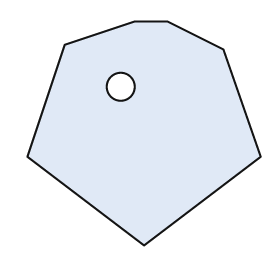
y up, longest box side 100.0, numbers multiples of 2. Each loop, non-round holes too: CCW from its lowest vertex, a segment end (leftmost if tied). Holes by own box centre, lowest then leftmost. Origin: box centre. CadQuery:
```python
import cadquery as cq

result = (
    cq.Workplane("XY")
    .moveTo(0.0, -48.0)
    .lineTo(50.0, -10.0)
    .lineTo(34.0, 36.0)
    .lineTo(10.0, 48.0)
    .lineTo(-4.0, 48.0)
    .lineTo(-34.0, 38.0)
    .lineTo(-50.0, -10.0)
    .close()
    .moveTo(-10.0, 20.0)
    .circle(6.0)
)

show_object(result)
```